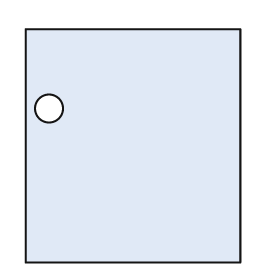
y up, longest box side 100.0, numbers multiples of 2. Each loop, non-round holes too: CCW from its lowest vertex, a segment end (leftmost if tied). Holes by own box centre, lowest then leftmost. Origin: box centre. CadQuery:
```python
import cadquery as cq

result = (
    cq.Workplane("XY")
    .moveTo(-46.0, -50.0)
    .lineTo(46.0, -50.0)
    .lineTo(46.0, 50.0)
    .lineTo(-46.0, 50.0)
    .close()
    .moveTo(-36.0, 16.0)
    .circle(6.0)
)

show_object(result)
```